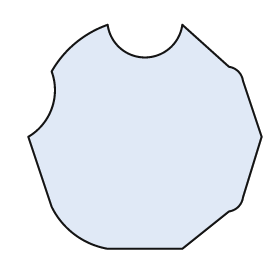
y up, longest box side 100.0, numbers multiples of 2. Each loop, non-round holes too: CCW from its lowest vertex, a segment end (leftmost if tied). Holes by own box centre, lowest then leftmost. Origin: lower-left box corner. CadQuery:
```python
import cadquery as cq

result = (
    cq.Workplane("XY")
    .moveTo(34.0, 0.0)
    .lineTo(66.0, 0.0)
    .lineTo(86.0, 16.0)
    .threePointArc((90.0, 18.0), (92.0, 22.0))
    .lineTo(100.0, 48.0)
    .lineTo(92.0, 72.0)
    .threePointArc((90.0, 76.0), (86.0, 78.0))
    .lineTo(66.0, 96.0)
    .threePointArc((50.0, 82.0), (34.0, 96.0))
    .threePointArc((20.0, 88.0), (10.0, 76.0))
    .threePointArc((10.0, 60.0), (0.0, 48.0))
    .lineTo(10.0, 18.0)
    .threePointArc((20.0, 6.0), (34.0, 0.0))
    .close()
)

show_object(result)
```